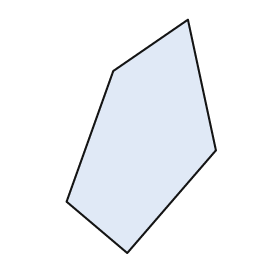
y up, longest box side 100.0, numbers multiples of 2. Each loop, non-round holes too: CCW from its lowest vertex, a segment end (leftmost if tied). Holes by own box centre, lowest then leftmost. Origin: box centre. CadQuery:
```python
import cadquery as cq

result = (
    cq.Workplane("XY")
    .moveTo(-6.0, -50.0)
    .lineTo(32.0, -6.0)
    .lineTo(20.0, 50.0)
    .lineTo(-12.0, 28.0)
    .lineTo(-32.0, -28.0)
    .close()
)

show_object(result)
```